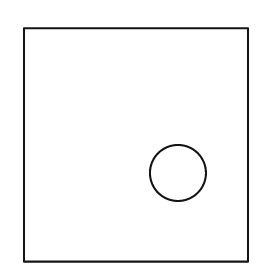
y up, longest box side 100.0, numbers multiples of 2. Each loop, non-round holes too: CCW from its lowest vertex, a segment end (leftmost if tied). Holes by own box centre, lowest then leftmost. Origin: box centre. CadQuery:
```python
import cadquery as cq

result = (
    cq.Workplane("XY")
    .moveTo(-48.0, -50.0)
    .lineTo(48.0, -50.0)
    .lineTo(48.0, 50.0)
    .lineTo(-48.0, 50.0)
    .close()
    .moveTo(18.0, -12.0)
    .circle(12.0)
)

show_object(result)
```